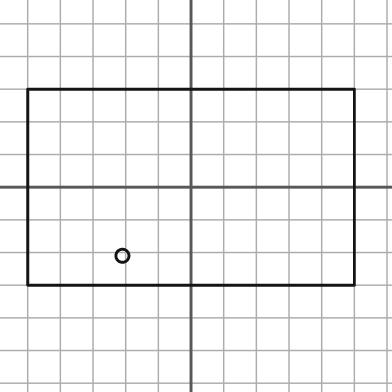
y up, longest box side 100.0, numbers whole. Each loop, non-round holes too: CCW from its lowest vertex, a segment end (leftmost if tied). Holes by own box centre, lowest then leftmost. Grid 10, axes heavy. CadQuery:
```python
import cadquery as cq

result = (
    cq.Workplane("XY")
    .moveTo(-50.0, -30.0)
    .lineTo(50.0, -30.0)
    .lineTo(50.0, 30.0)
    .lineTo(-50.0, 30.0)
    .close()
    .moveTo(-21.0, -21.0)
    .circle(2.0)
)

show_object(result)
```